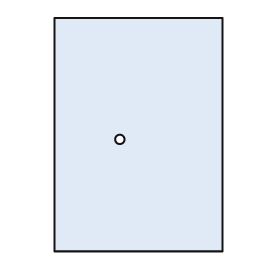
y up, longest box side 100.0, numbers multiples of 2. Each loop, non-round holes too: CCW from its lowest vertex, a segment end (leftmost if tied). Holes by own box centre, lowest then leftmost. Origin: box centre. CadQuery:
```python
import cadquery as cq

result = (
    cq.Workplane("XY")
    .moveTo(-36.0, -50.0)
    .lineTo(36.0, -50.0)
    .lineTo(36.0, 50.0)
    .lineTo(-36.0, 50.0)
    .close()
    .moveTo(-8.0, -2.0)
    .circle(2.0)
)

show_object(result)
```